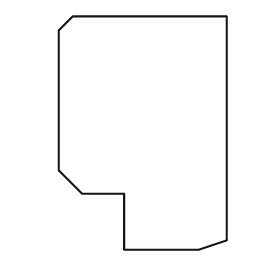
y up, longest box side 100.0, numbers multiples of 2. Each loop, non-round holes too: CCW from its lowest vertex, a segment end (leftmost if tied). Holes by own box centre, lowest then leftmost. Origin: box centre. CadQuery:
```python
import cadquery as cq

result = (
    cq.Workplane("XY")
    .moveTo(-8.0, -50.0)
    .lineTo(24.0, -50.0)
    .lineTo(36.0, -46.0)
    .lineTo(36.0, 50.0)
    .lineTo(-30.0, 50.0)
    .lineTo(-36.0, 44.0)
    .lineTo(-36.0, -16.0)
    .lineTo(-26.0, -26.0)
    .lineTo(-8.0, -26.0)
    .close()
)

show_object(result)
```